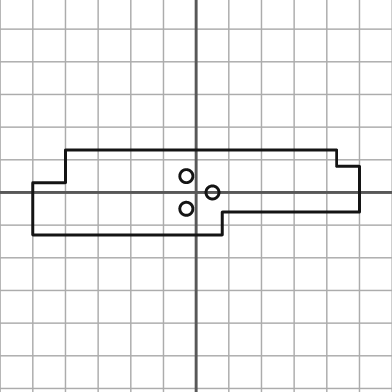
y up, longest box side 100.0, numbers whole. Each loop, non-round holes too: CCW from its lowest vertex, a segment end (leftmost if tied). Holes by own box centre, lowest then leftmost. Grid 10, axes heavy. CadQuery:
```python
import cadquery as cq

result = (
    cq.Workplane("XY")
    .moveTo(-50.0, -13.0)
    .lineTo(8.0, -13.0)
    .lineTo(8.0, -6.0)
    .lineTo(50.0, -6.0)
    .lineTo(50.0, 8.0)
    .lineTo(43.0, 8.0)
    .lineTo(43.0, 13.0)
    .lineTo(-40.0, 13.0)
    .lineTo(-40.0, 3.0)
    .lineTo(-50.0, 3.0)
    .close()
    .moveTo(-3.0, -5.0)
    .circle(2.0)
    .moveTo(5.0, 0.0)
    .circle(2.0)
    .moveTo(-3.0, 5.0)
    .circle(2.0)
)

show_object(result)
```